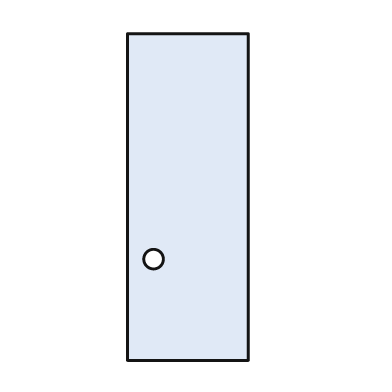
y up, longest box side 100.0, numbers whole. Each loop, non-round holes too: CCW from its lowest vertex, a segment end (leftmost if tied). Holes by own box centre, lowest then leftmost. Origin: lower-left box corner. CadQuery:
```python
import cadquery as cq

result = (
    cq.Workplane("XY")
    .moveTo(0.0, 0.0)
    .lineTo(37.0, 0.0)
    .lineTo(37.0, 100.0)
    .lineTo(0.0, 100.0)
    .close()
    .moveTo(8.0, 31.0)
    .circle(3.0)
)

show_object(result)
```